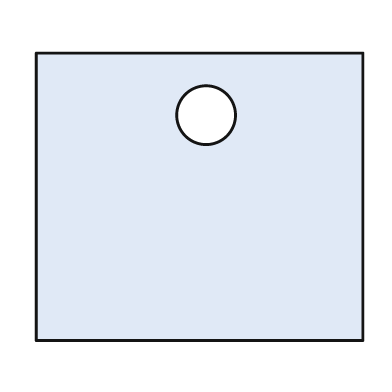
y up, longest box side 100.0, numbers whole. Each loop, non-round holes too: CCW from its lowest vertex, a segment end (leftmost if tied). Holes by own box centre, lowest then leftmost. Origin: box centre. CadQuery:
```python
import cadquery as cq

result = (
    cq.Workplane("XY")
    .moveTo(-50.0, -44.0)
    .lineTo(50.0, -44.0)
    .lineTo(50.0, 44.0)
    .lineTo(-50.0, 44.0)
    .close()
    .moveTo(2.0, 25.0)
    .circle(9.0)
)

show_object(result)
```